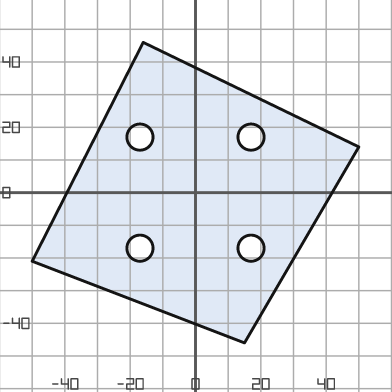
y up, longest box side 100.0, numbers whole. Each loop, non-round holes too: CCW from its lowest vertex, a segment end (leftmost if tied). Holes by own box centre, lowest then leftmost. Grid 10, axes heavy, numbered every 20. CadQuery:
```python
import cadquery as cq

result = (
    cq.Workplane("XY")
    .moveTo(15.0, -46.0)
    .lineTo(50.0, 14.0)
    .lineTo(-16.0, 46.0)
    .lineTo(-50.0, -21.0)
    .close()
    .moveTo(-17.0, -17.0)
    .circle(4.0)
    .moveTo(17.0, -17.0)
    .circle(4.0)
    .moveTo(-17.0, 17.0)
    .circle(4.0)
    .moveTo(17.0, 17.0)
    .circle(4.0)
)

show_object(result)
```